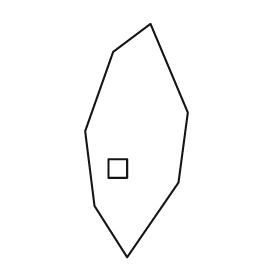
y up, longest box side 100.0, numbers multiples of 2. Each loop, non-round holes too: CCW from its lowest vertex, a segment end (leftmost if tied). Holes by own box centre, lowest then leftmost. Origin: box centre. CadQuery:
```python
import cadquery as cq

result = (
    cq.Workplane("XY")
    .moveTo(-4.0, -50.0)
    .lineTo(18.0, -18.0)
    .lineTo(22.0, 12.0)
    .lineTo(6.0, 50.0)
    .lineTo(-10.0, 38.0)
    .lineTo(-22.0, 4.0)
    .lineTo(-18.0, -28.0)
    .close()
    .moveTo(-12.0, -16.0)
    .lineTo(-4.0, -16.0)
    .lineTo(-4.0, -8.0)
    .lineTo(-12.0, -8.0)
    .close()
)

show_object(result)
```